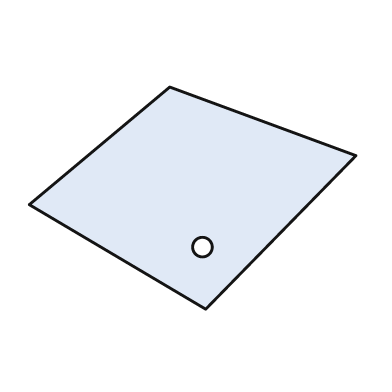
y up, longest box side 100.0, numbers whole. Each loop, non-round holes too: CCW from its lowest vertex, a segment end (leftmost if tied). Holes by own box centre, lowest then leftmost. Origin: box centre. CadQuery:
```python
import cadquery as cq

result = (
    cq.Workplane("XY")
    .moveTo(4.0, -34.0)
    .lineTo(50.0, 13.0)
    .lineTo(-7.0, 34.0)
    .lineTo(-50.0, -2.0)
    .close()
    .moveTo(3.0, -15.0)
    .circle(3.0)
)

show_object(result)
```